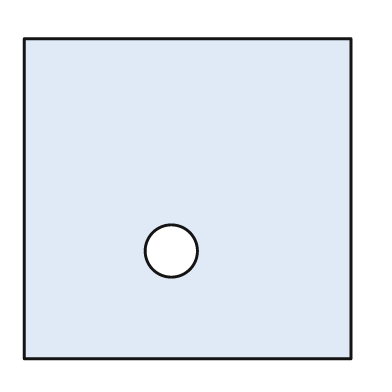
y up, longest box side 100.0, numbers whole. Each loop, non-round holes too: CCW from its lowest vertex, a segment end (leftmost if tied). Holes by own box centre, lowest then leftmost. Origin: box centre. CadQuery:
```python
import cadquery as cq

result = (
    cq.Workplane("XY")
    .moveTo(-50.0, -49.0)
    .lineTo(50.0, -49.0)
    .lineTo(50.0, 49.0)
    .lineTo(-50.0, 49.0)
    .close()
    .moveTo(-5.0, -16.0)
    .circle(8.0)
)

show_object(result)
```